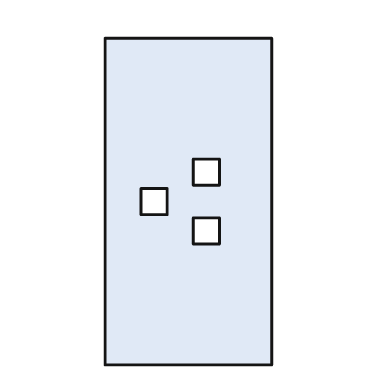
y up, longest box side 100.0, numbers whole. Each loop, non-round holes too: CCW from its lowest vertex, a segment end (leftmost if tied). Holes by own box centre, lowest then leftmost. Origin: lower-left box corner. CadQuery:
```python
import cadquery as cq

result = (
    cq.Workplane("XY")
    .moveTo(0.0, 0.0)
    .lineTo(51.0, 0.0)
    .lineTo(51.0, 100.0)
    .lineTo(0.0, 100.0)
    .close()
    .moveTo(27.0, 37.0)
    .lineTo(35.0, 37.0)
    .lineTo(35.0, 45.0)
    .lineTo(27.0, 45.0)
    .close()
    .moveTo(11.0, 46.0)
    .lineTo(19.0, 46.0)
    .lineTo(19.0, 54.0)
    .lineTo(11.0, 54.0)
    .close()
    .moveTo(27.0, 55.0)
    .lineTo(35.0, 55.0)
    .lineTo(35.0, 63.0)
    .lineTo(27.0, 63.0)
    .close()
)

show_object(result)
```